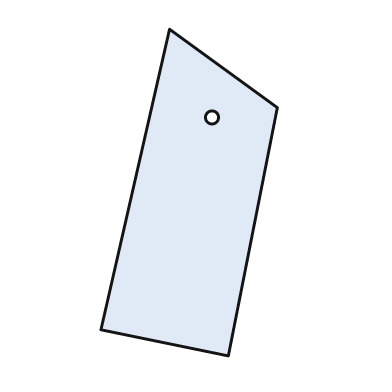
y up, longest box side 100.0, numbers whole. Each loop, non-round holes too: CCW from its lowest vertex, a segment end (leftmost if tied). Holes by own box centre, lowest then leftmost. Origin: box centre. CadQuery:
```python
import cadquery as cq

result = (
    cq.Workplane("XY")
    .moveTo(12.0, -50.0)
    .lineTo(27.0, 26.0)
    .lineTo(-6.0, 50.0)
    .lineTo(-27.0, -42.0)
    .close()
    .moveTo(7.0, 23.0)
    .circle(2.0)
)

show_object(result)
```